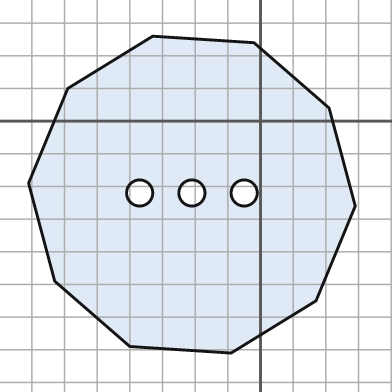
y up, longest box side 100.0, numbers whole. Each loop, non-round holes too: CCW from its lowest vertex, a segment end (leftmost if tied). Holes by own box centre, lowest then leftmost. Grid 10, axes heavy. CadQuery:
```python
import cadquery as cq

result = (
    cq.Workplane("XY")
    .moveTo(-9.0, -71.0)
    .lineTo(17.0, -55.0)
    .lineTo(29.0, -26.0)
    .lineTo(21.0, 4.0)
    .lineTo(-2.0, 24.0)
    .lineTo(-33.0, 26.0)
    .lineTo(-59.0, 10.0)
    .lineTo(-71.0, -19.0)
    .lineTo(-63.0, -49.0)
    .lineTo(-40.0, -69.0)
    .close()
    .moveTo(-37.0, -22.0)
    .circle(4.0)
    .moveTo(-21.0, -22.0)
    .circle(4.0)
    .moveTo(-5.0, -22.0)
    .circle(4.0)
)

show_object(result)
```